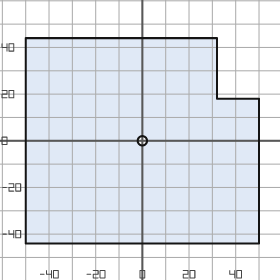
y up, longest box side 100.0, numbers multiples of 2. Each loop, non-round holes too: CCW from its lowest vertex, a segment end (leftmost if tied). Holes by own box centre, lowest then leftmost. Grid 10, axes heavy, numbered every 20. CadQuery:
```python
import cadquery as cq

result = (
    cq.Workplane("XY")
    .moveTo(-50.0, -44.0)
    .lineTo(50.0, -44.0)
    .lineTo(50.0, 18.0)
    .lineTo(32.0, 18.0)
    .lineTo(32.0, 44.0)
    .lineTo(-50.0, 44.0)
    .close()
    .moveTo(0.0, 0.0)
    .circle(2.0)
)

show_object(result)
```